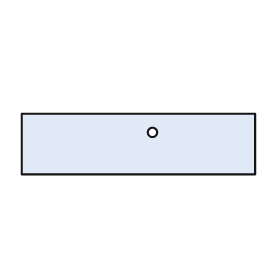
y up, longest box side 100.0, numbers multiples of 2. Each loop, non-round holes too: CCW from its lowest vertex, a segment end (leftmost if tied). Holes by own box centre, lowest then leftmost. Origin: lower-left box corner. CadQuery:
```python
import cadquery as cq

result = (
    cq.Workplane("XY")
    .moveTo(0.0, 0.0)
    .lineTo(100.0, 0.0)
    .lineTo(100.0, 26.0)
    .lineTo(0.0, 26.0)
    .close()
    .moveTo(56.0, 18.0)
    .circle(2.0)
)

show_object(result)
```